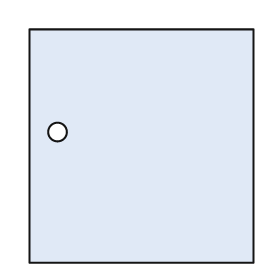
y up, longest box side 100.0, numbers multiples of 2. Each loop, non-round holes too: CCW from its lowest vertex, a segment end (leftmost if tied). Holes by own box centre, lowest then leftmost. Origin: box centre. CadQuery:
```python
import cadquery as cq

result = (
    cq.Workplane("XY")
    .moveTo(-48.0, -50.0)
    .lineTo(48.0, -50.0)
    .lineTo(48.0, 50.0)
    .lineTo(-48.0, 50.0)
    .close()
    .moveTo(-36.0, 6.0)
    .circle(4.0)
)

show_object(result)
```